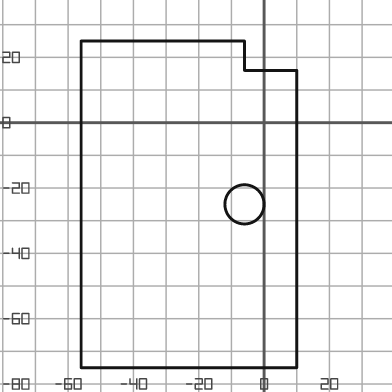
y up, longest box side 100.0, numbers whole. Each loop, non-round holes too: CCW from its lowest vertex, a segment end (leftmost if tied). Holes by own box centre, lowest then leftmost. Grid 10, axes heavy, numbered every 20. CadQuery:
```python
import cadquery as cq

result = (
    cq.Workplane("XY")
    .moveTo(-56.0, -75.0)
    .lineTo(10.0, -75.0)
    .lineTo(10.0, 16.0)
    .lineTo(-6.0, 16.0)
    .lineTo(-6.0, 25.0)
    .lineTo(-56.0, 25.0)
    .close()
    .moveTo(-6.0, -25.0)
    .circle(6.0)
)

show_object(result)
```